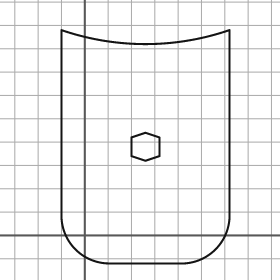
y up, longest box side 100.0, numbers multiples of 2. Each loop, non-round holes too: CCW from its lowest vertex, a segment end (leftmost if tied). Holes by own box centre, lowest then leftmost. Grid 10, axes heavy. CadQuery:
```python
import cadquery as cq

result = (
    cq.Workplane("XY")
    .moveTo(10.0, -12.0)
    .lineTo(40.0, -12.0)
    .threePointArc((56.0, -6.0), (62.0, 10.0))
    .lineTo(62.0, 88.0)
    .threePointArc((26.0, 82.0), (-10.0, 88.0))
    .lineTo(-10.0, 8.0)
    .threePointArc((-4.0, -6.0), (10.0, -12.0))
    .close()
    .moveTo(26.0, 32.0)
    .lineTo(32.0, 34.0)
    .lineTo(32.0, 42.0)
    .lineTo(26.0, 44.0)
    .lineTo(20.0, 42.0)
    .lineTo(20.0, 34.0)
    .close()
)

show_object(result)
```